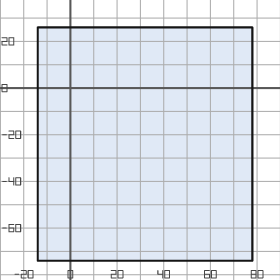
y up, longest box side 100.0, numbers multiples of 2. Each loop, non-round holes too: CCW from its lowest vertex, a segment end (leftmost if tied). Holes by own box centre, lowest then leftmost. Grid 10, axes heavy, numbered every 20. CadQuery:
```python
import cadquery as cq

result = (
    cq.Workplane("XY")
    .moveTo(-14.0, -74.0)
    .lineTo(78.0, -74.0)
    .lineTo(78.0, 26.0)
    .lineTo(-14.0, 26.0)
    .close()
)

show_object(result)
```